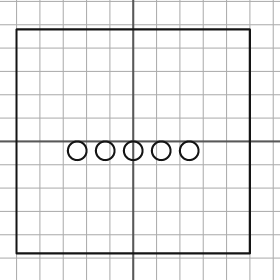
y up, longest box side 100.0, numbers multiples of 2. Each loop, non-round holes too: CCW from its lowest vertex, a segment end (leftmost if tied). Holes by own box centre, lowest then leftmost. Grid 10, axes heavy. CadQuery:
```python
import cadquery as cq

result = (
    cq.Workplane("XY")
    .moveTo(-50.0, -48.0)
    .lineTo(50.0, -48.0)
    .lineTo(50.0, 48.0)
    .lineTo(-50.0, 48.0)
    .close()
    .moveTo(-24.0, -4.0)
    .circle(4.0)
    .moveTo(-12.0, -4.0)
    .circle(4.0)
    .moveTo(0.0, -4.0)
    .circle(4.0)
    .moveTo(12.0, -4.0)
    .circle(4.0)
    .moveTo(24.0, -4.0)
    .circle(4.0)
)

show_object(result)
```